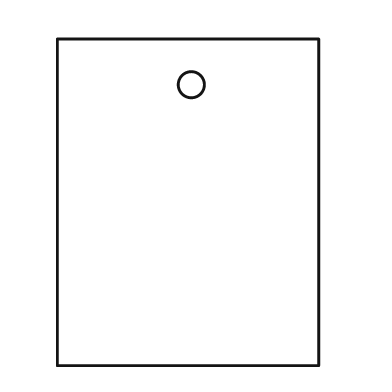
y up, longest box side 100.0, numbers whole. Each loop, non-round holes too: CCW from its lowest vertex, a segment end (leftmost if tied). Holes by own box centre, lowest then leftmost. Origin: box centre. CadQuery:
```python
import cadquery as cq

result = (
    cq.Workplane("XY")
    .moveTo(-40.0, -50.0)
    .lineTo(40.0, -50.0)
    .lineTo(40.0, 50.0)
    .lineTo(-40.0, 50.0)
    .close()
    .moveTo(1.0, 36.0)
    .circle(4.0)
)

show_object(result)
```